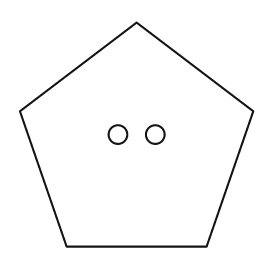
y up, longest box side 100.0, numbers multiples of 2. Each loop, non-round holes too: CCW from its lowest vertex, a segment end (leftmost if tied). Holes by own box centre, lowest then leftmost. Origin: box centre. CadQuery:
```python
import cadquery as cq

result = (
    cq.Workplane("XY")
    .moveTo(-30.0, -48.0)
    .lineTo(30.0, -48.0)
    .lineTo(50.0, 10.0)
    .lineTo(0.0, 48.0)
    .lineTo(-50.0, 10.0)
    .close()
    .moveTo(-8.0, 0.0)
    .circle(4.0)
    .moveTo(8.0, 0.0)
    .circle(4.0)
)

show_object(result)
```